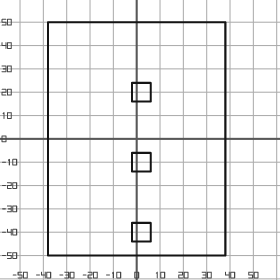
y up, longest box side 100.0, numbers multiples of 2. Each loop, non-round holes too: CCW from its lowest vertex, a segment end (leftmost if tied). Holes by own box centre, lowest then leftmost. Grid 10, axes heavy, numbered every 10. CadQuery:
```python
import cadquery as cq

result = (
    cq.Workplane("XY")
    .moveTo(-38.0, -50.0)
    .lineTo(38.0, -50.0)
    .lineTo(38.0, 50.0)
    .lineTo(-38.0, 50.0)
    .close()
    .moveTo(-2.0, -44.0)
    .lineTo(6.0, -44.0)
    .lineTo(6.0, -36.0)
    .lineTo(-2.0, -36.0)
    .close()
    .moveTo(-2.0, -14.0)
    .lineTo(6.0, -14.0)
    .lineTo(6.0, -6.0)
    .lineTo(-2.0, -6.0)
    .close()
    .moveTo(-2.0, 16.0)
    .lineTo(6.0, 16.0)
    .lineTo(6.0, 24.0)
    .lineTo(-2.0, 24.0)
    .close()
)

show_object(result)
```